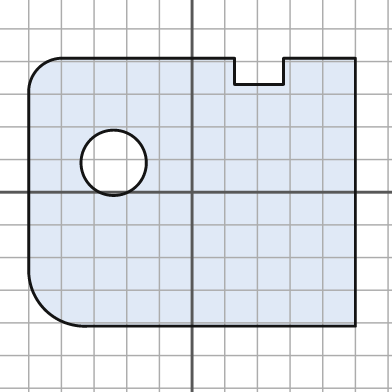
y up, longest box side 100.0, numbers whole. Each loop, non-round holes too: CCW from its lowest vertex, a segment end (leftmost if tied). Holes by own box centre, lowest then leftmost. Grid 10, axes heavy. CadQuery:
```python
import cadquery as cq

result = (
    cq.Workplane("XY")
    .moveTo(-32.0, -41.0)
    .lineTo(50.0, -41.0)
    .lineTo(50.0, 41.0)
    .lineTo(28.0, 41.0)
    .lineTo(28.0, 33.0)
    .lineTo(13.0, 33.0)
    .lineTo(13.0, 41.0)
    .lineTo(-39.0, 41.0)
    .threePointArc((-47.0, 38.0), (-50.0, 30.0))
    .lineTo(-50.0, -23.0)
    .threePointArc((-45.0, -36.0), (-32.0, -41.0))
    .close()
    .moveTo(-24.0, 9.0)
    .circle(10.0)
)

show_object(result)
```